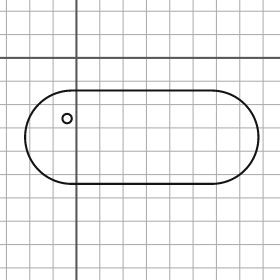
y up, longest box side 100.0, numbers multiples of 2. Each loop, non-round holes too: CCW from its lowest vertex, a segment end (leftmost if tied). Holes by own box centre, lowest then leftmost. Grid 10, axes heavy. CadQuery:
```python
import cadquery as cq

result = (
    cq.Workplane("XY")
    .moveTo(-2.0, -54.0)
    .lineTo(58.0, -54.0)
    .threePointArc((78.0, -34.0), (58.0, -14.0))
    .lineTo(-2.0, -14.0)
    .threePointArc((-22.0, -34.0), (-2.0, -54.0))
    .close()
    .moveTo(-4.0, -26.0)
    .circle(2.0)
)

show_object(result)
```